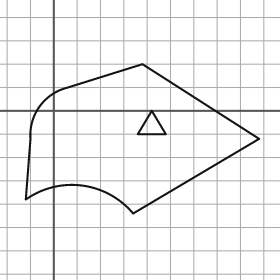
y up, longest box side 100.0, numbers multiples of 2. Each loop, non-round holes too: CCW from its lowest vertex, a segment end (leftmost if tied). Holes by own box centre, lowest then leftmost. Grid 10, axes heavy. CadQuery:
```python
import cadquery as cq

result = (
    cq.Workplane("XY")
    .moveTo(34.0, -44.0)
    .lineTo(88.0, -12.0)
    .lineTo(38.0, 20.0)
    .lineTo(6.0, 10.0)
    .threePointArc((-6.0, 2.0), (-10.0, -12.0))
    .lineTo(-12.0, -38.0)
    .threePointArc((12.0, -32.0), (34.0, -44.0))
    .close()
    .moveTo(36.0, -10.0)
    .lineTo(48.0, -10.0)
    .lineTo(42.0, 0.0)
    .close()
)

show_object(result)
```